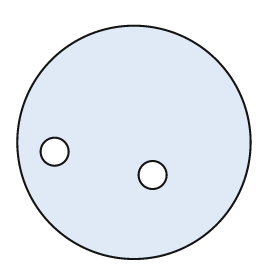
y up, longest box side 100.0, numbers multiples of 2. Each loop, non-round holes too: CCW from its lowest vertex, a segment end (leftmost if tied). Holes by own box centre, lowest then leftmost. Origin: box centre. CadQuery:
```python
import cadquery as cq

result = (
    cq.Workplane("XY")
    .moveTo(0.0, 0.0)
    .circle(50.0)
    .moveTo(8.0, -14.0)
    .circle(6.0)
    .moveTo(-34.0, -4.0)
    .circle(6.0)
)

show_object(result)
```